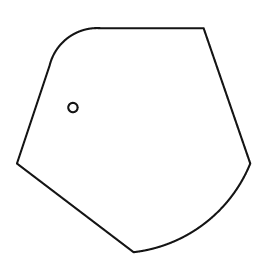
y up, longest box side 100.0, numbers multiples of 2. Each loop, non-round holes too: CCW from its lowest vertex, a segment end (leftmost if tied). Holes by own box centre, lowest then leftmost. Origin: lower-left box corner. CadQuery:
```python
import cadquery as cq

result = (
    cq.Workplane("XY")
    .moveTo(50.0, 0.0)
    .threePointArc((80.0, 12.0), (100.0, 38.0))
    .lineTo(80.0, 96.0)
    .lineTo(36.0, 96.0)
    .threePointArc((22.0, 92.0), (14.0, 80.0))
    .lineTo(0.0, 38.0)
    .close()
    .moveTo(24.0, 62.0)
    .circle(2.0)
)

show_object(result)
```